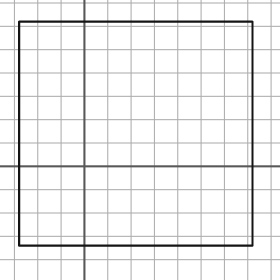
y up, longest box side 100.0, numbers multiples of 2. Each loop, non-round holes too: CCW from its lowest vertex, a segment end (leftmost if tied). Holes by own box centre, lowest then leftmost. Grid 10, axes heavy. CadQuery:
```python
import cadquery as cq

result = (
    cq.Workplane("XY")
    .moveTo(-28.0, -34.0)
    .lineTo(72.0, -34.0)
    .lineTo(72.0, 62.0)
    .lineTo(-28.0, 62.0)
    .close()
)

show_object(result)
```